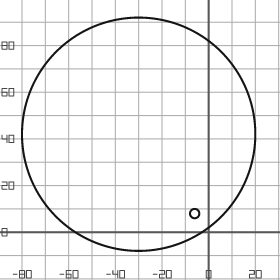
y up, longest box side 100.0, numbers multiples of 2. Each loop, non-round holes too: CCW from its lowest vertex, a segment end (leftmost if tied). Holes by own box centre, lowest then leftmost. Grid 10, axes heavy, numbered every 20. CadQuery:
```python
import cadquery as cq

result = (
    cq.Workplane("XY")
    .moveTo(-30.0, 42.0)
    .circle(50.0)
    .moveTo(-6.0, 8.0)
    .circle(2.0)
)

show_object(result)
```